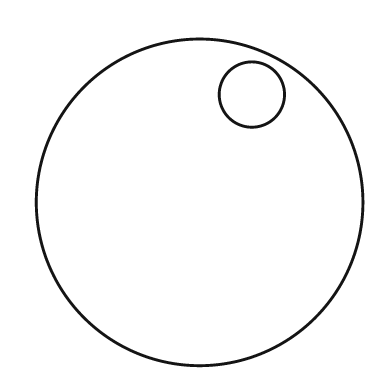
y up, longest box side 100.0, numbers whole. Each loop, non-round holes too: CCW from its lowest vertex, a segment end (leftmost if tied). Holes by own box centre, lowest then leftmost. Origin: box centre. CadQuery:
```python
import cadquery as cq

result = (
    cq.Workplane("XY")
    .moveTo(0.0, 0.0)
    .circle(50.0)
    .moveTo(16.0, 33.0)
    .circle(10.0)
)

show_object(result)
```